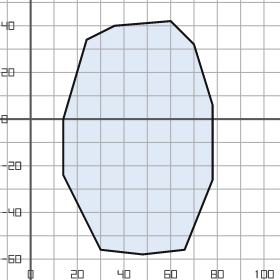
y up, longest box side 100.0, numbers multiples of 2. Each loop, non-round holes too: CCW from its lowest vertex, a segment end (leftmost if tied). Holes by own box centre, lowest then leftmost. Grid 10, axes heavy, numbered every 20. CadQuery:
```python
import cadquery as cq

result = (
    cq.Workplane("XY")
    .moveTo(48.0, -58.0)
    .lineTo(66.0, -56.0)
    .lineTo(78.0, -26.0)
    .lineTo(78.0, 6.0)
    .lineTo(70.0, 32.0)
    .lineTo(60.0, 42.0)
    .lineTo(36.0, 40.0)
    .lineTo(24.0, 34.0)
    .lineTo(14.0, 0.0)
    .lineTo(14.0, -24.0)
    .lineTo(30.0, -56.0)
    .close()
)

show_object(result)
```